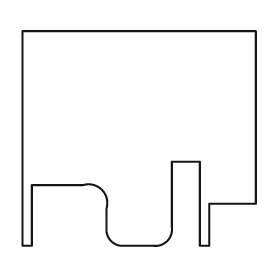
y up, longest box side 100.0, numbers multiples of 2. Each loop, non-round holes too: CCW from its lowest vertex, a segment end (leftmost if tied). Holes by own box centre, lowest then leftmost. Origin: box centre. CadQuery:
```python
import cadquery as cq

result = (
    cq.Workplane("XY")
    .moveTo(-50.0, -46.0)
    .lineTo(-46.0, -46.0)
    .lineTo(-46.0, -20.0)
    .lineTo(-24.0, -20.0)
    .threePointArc((-16.0, -22.0), (-14.0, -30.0))
    .lineTo(-14.0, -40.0)
    .threePointArc((-12.0, -44.0), (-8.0, -46.0))
    .lineTo(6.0, -46.0)
    .threePointArc((12.0, -44.0), (14.0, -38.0))
    .lineTo(14.0, -10.0)
    .lineTo(26.0, -10.0)
    .lineTo(26.0, -46.0)
    .lineTo(30.0, -46.0)
    .lineTo(30.0, -28.0)
    .lineTo(50.0, -28.0)
    .lineTo(50.0, 46.0)
    .lineTo(-50.0, 46.0)
    .close()
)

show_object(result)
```